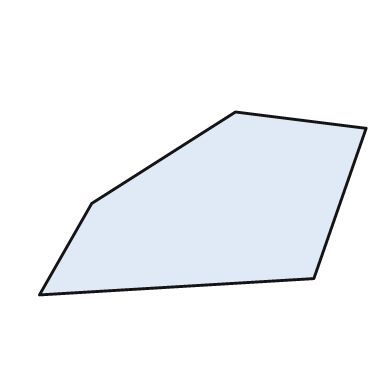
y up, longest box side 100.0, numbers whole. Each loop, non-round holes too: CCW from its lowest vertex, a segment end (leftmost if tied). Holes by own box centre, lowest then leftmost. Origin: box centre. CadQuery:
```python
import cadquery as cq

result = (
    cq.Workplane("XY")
    .moveTo(-50.0, -28.0)
    .lineTo(34.0, -23.0)
    .lineTo(50.0, 23.0)
    .lineTo(10.0, 28.0)
    .lineTo(-34.0, 0.0)
    .close()
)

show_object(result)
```